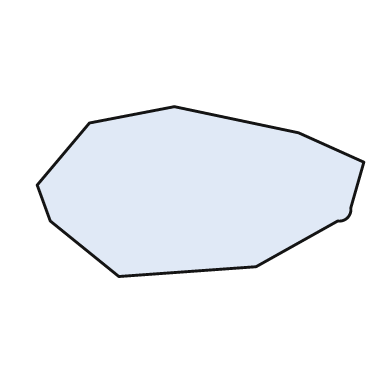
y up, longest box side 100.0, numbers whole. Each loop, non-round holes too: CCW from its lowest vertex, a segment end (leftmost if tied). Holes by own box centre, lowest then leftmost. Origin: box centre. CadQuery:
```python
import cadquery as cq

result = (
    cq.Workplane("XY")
    .moveTo(-25.0, -26.0)
    .lineTo(17.0, -23.0)
    .lineTo(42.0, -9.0)
    .threePointArc((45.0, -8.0), (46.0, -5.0))
    .lineTo(50.0, 9.0)
    .lineTo(30.0, 18.0)
    .lineTo(-8.0, 26.0)
    .lineTo(-34.0, 21.0)
    .lineTo(-50.0, 2.0)
    .lineTo(-46.0, -9.0)
    .close()
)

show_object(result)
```